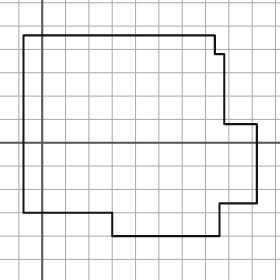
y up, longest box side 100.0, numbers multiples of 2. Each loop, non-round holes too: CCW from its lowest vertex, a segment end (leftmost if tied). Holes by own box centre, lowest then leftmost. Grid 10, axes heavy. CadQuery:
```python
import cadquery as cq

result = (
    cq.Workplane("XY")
    .moveTo(30.0, -40.0)
    .lineTo(76.0, -40.0)
    .lineTo(76.0, -26.0)
    .lineTo(92.0, -26.0)
    .lineTo(92.0, 8.0)
    .lineTo(78.0, 8.0)
    .lineTo(78.0, 38.0)
    .lineTo(74.0, 38.0)
    .lineTo(74.0, 46.0)
    .lineTo(-8.0, 46.0)
    .lineTo(-8.0, -30.0)
    .lineTo(30.0, -30.0)
    .close()
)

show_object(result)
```